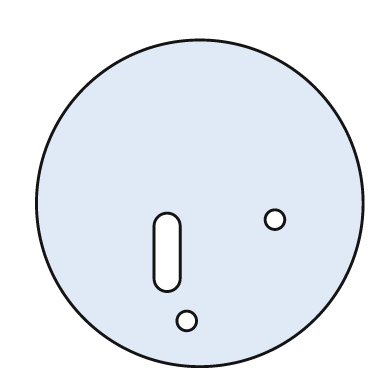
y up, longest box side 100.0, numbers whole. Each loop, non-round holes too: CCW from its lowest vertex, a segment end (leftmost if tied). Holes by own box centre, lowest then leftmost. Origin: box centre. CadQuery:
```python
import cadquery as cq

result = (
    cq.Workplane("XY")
    .moveTo(0.0, 0.0)
    .circle(50.0)
    .moveTo(-4.0, -36.0)
    .circle(3.0)
    .moveTo(-14.0, -23.0)
    .threePointArc((-10.0, -27.0), (-6.0, -23.0))
    .lineTo(-6.0, -7.0)
    .threePointArc((-10.0, -3.0), (-14.0, -7.0))
    .close()
    .moveTo(23.0, -5.0)
    .circle(3.0)
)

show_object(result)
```